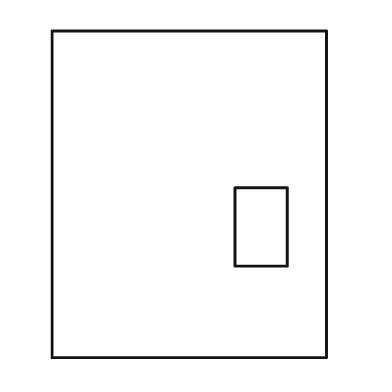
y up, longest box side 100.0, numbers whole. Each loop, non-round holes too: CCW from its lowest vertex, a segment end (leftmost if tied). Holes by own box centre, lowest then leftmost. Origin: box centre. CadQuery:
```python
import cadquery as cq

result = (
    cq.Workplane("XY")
    .moveTo(-42.0, -50.0)
    .lineTo(42.0, -50.0)
    .lineTo(42.0, 50.0)
    .lineTo(-42.0, 50.0)
    .close()
    .moveTo(14.0, -22.0)
    .lineTo(30.0, -22.0)
    .lineTo(30.0, 2.0)
    .lineTo(14.0, 2.0)
    .close()
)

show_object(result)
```